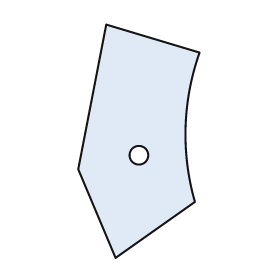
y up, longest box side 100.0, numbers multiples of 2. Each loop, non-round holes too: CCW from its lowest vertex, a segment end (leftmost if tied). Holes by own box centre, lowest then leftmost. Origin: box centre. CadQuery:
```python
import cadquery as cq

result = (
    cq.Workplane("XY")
    .moveTo(-10.0, -50.0)
    .lineTo(24.0, -26.0)
    .threePointArc((20.0, 6.0), (26.0, 38.0))
    .lineTo(-14.0, 50.0)
    .lineTo(-26.0, -12.0)
    .close()
    .moveTo(0.0, -6.0)
    .circle(4.0)
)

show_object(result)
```